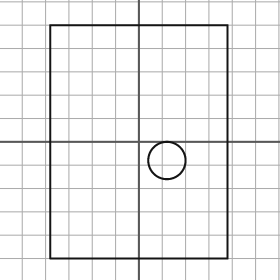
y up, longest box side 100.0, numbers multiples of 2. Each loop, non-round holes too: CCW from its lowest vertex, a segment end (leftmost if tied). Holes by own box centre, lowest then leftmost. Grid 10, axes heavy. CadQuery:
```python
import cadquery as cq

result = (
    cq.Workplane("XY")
    .moveTo(-38.0, -50.0)
    .lineTo(38.0, -50.0)
    .lineTo(38.0, 50.0)
    .lineTo(-38.0, 50.0)
    .close()
    .moveTo(12.0, -8.0)
    .circle(8.0)
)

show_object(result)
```